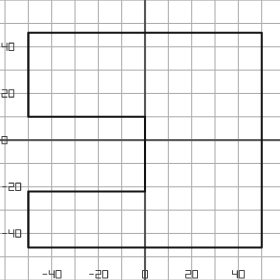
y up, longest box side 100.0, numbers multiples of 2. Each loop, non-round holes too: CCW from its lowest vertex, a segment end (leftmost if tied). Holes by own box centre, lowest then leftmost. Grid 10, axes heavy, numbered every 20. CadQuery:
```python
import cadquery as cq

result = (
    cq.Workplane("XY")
    .moveTo(-50.0, -46.0)
    .lineTo(50.0, -46.0)
    .lineTo(50.0, 46.0)
    .lineTo(-50.0, 46.0)
    .lineTo(-50.0, 10.0)
    .lineTo(0.0, 10.0)
    .lineTo(0.0, -22.0)
    .lineTo(-50.0, -22.0)
    .close()
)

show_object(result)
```